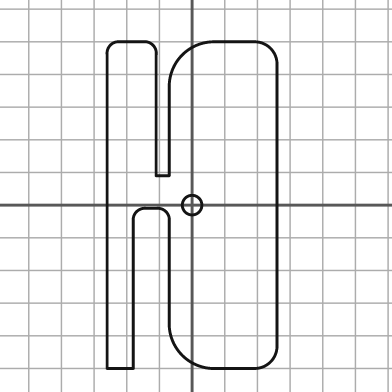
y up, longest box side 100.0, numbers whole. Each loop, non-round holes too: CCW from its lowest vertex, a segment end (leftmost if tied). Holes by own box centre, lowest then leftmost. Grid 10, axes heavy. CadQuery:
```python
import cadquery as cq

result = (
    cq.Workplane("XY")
    .moveTo(-26.0, -50.0)
    .lineTo(-18.0, -50.0)
    .lineTo(-18.0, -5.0)
    .threePointArc((-17.0, -2.0), (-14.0, -1.0))
    .lineTo(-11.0, -1.0)
    .threePointArc((-8.0, -2.0), (-7.0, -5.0))
    .lineTo(-7.0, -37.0)
    .threePointArc((-3.0, -46.0), (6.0, -50.0))
    .lineTo(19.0, -50.0)
    .threePointArc((24.0, -48.0), (26.0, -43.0))
    .lineTo(26.0, 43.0)
    .threePointArc((24.0, 48.0), (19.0, 50.0))
    .lineTo(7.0, 50.0)
    .threePointArc((-3.0, 46.0), (-7.0, 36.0))
    .lineTo(-7.0, 9.0)
    .lineTo(-11.0, 9.0)
    .lineTo(-11.0, 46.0)
    .threePointArc((-12.0, 49.0), (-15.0, 50.0))
    .lineTo(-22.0, 50.0)
    .threePointArc((-25.0, 49.0), (-26.0, 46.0))
    .close()
    .moveTo(0.0, 0.0)
    .circle(3.0)
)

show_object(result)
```